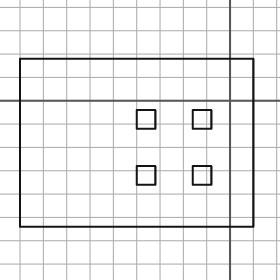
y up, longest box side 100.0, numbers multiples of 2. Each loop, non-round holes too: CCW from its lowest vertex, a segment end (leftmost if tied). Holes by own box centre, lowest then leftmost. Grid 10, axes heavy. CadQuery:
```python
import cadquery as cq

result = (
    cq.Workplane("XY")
    .moveTo(-90.0, -54.0)
    .lineTo(10.0, -54.0)
    .lineTo(10.0, 18.0)
    .lineTo(-90.0, 18.0)
    .close()
    .moveTo(-40.0, -36.0)
    .lineTo(-32.0, -36.0)
    .lineTo(-32.0, -28.0)
    .lineTo(-40.0, -28.0)
    .close()
    .moveTo(-16.0, -36.0)
    .lineTo(-8.0, -36.0)
    .lineTo(-8.0, -28.0)
    .lineTo(-16.0, -28.0)
    .close()
    .moveTo(-40.0, -12.0)
    .lineTo(-32.0, -12.0)
    .lineTo(-32.0, -4.0)
    .lineTo(-40.0, -4.0)
    .close()
    .moveTo(-16.0, -12.0)
    .lineTo(-8.0, -12.0)
    .lineTo(-8.0, -4.0)
    .lineTo(-16.0, -4.0)
    .close()
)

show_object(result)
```